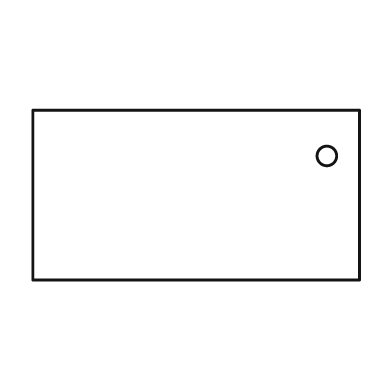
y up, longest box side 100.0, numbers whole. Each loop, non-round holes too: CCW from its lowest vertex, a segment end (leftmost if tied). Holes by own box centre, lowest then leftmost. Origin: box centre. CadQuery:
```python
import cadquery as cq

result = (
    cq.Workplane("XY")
    .moveTo(-50.0, -26.0)
    .lineTo(50.0, -26.0)
    .lineTo(50.0, 26.0)
    .lineTo(-50.0, 26.0)
    .close()
    .moveTo(40.0, 12.0)
    .circle(3.0)
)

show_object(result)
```